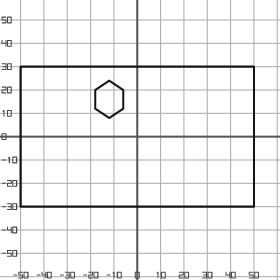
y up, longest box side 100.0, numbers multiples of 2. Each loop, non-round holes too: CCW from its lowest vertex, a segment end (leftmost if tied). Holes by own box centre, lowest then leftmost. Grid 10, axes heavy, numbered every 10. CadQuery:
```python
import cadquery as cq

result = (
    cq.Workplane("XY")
    .moveTo(-50.0, -30.0)
    .lineTo(50.0, -30.0)
    .lineTo(50.0, 30.0)
    .lineTo(-50.0, 30.0)
    .close()
    .moveTo(-12.0, 8.0)
    .lineTo(-6.0, 12.0)
    .lineTo(-6.0, 20.0)
    .lineTo(-12.0, 24.0)
    .lineTo(-18.0, 20.0)
    .lineTo(-18.0, 12.0)
    .close()
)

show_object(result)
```